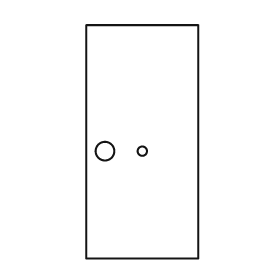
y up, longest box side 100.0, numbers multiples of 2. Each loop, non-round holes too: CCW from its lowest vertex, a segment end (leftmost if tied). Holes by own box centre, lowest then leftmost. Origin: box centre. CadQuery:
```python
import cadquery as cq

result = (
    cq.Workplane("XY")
    .moveTo(-24.0, -50.0)
    .lineTo(24.0, -50.0)
    .lineTo(24.0, 50.0)
    .lineTo(-24.0, 50.0)
    .close()
    .moveTo(-16.0, -4.0)
    .circle(4.0)
    .moveTo(0.0, -4.0)
    .circle(2.0)
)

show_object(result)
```